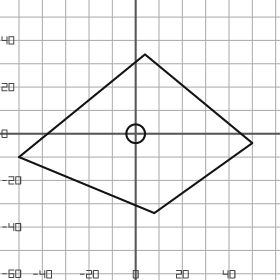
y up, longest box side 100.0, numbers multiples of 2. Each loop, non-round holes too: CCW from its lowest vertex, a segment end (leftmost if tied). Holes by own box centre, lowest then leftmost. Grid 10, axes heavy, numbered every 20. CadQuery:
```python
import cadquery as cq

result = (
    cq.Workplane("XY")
    .moveTo(8.0, -34.0)
    .lineTo(50.0, -4.0)
    .lineTo(4.0, 34.0)
    .lineTo(-50.0, -10.0)
    .close()
    .moveTo(0.0, 0.0)
    .circle(4.0)
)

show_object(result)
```